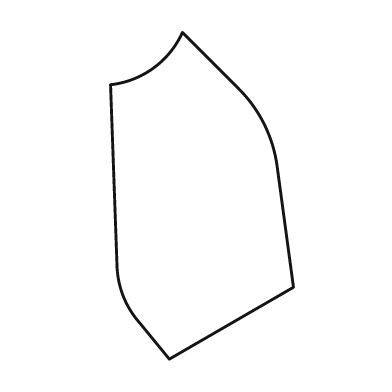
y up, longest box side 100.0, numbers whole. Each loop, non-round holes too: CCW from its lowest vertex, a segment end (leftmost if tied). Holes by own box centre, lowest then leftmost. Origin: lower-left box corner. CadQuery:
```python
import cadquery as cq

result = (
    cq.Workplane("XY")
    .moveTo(18.0, 0.0)
    .lineTo(56.0, 22.0)
    .lineTo(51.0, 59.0)
    .threePointArc((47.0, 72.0), (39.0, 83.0))
    .lineTo(22.0, 100.0)
    .threePointArc((13.0, 89.0), (0.0, 84.0))
    .lineTo(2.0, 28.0)
    .threePointArc((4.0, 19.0), (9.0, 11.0))
    .close()
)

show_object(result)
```